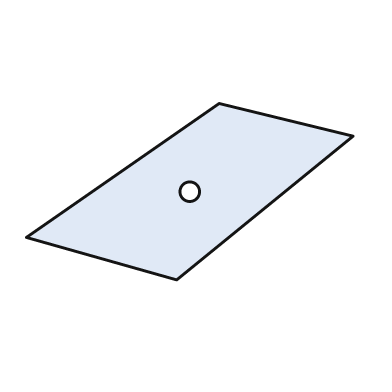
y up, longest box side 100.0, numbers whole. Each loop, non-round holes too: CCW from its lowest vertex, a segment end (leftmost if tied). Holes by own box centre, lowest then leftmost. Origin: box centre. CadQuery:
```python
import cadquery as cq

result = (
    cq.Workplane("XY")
    .moveTo(-4.0, -27.0)
    .lineTo(50.0, 17.0)
    .lineTo(9.0, 27.0)
    .lineTo(-50.0, -14.0)
    .close()
    .moveTo(0.0, 0.0)
    .circle(3.0)
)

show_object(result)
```